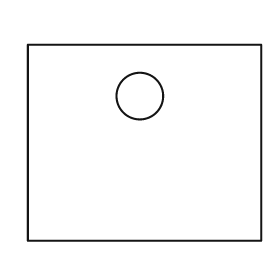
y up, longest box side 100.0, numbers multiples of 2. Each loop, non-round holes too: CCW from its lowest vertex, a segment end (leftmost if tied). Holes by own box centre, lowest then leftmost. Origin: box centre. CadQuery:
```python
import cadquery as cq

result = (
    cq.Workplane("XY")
    .moveTo(-50.0, -42.0)
    .lineTo(50.0, -42.0)
    .lineTo(50.0, 42.0)
    .lineTo(-50.0, 42.0)
    .close()
    .moveTo(-2.0, 20.0)
    .circle(10.0)
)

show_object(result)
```